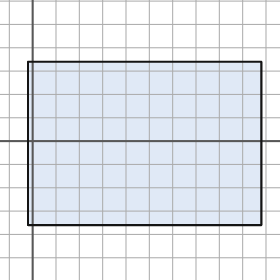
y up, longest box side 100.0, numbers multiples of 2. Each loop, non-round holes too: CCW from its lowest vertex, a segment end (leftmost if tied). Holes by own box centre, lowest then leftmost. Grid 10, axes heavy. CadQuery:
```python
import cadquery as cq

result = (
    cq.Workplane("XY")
    .moveTo(-2.0, -36.0)
    .lineTo(98.0, -36.0)
    .lineTo(98.0, 34.0)
    .lineTo(-2.0, 34.0)
    .close()
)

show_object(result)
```